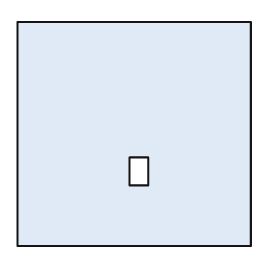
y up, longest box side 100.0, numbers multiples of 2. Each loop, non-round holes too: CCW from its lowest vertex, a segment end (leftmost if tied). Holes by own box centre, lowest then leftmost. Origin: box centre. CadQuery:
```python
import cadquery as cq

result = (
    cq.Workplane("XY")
    .moveTo(-50.0, -48.0)
    .lineTo(50.0, -48.0)
    .lineTo(50.0, 48.0)
    .lineTo(-50.0, 48.0)
    .close()
    .moveTo(-2.0, -22.0)
    .lineTo(6.0, -22.0)
    .lineTo(6.0, -10.0)
    .lineTo(-2.0, -10.0)
    .close()
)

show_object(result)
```